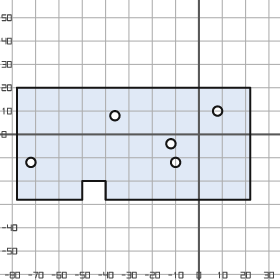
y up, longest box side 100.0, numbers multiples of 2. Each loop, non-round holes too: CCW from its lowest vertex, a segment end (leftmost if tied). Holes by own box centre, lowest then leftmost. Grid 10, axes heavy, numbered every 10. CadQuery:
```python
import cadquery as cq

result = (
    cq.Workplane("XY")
    .moveTo(-78.0, -28.0)
    .lineTo(-50.0, -28.0)
    .lineTo(-50.0, -20.0)
    .lineTo(-40.0, -20.0)
    .lineTo(-40.0, -28.0)
    .lineTo(22.0, -28.0)
    .lineTo(22.0, 20.0)
    .lineTo(-78.0, 20.0)
    .close()
    .moveTo(-72.0, -12.0)
    .circle(2.0)
    .moveTo(-10.0, -12.0)
    .circle(2.0)
    .moveTo(-12.0, -4.0)
    .circle(2.0)
    .moveTo(-36.0, 8.0)
    .circle(2.0)
    .moveTo(8.0, 10.0)
    .circle(2.0)
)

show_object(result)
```